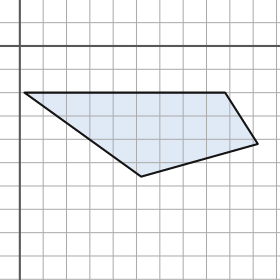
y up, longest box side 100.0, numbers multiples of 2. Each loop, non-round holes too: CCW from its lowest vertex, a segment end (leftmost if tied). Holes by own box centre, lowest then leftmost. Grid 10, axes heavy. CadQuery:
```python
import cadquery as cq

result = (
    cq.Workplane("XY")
    .moveTo(52.0, -56.0)
    .lineTo(102.0, -42.0)
    .lineTo(88.0, -20.0)
    .lineTo(2.0, -20.0)
    .close()
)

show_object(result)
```